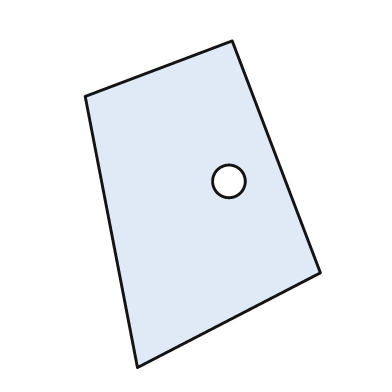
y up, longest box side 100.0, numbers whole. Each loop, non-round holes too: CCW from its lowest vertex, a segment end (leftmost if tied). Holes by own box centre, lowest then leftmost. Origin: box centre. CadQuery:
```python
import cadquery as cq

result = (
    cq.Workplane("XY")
    .moveTo(-20.0, -50.0)
    .lineTo(36.0, -21.0)
    .lineTo(9.0, 50.0)
    .lineTo(-36.0, 33.0)
    .close()
    .moveTo(8.0, 7.0)
    .circle(5.0)
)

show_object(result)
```